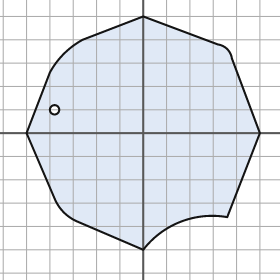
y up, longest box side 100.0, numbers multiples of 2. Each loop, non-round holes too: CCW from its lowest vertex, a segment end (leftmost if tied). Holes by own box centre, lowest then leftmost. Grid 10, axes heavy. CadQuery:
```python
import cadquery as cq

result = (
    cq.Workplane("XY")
    .moveTo(0.0, -50.0)
    .threePointArc((16.0, -38.0), (36.0, -36.0))
    .lineTo(50.0, 0.0)
    .lineTo(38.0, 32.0)
    .threePointArc((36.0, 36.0), (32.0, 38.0))
    .lineTo(0.0, 50.0)
    .lineTo(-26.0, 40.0)
    .threePointArc((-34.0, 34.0), (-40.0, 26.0))
    .lineTo(-50.0, 0.0)
    .lineTo(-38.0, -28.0)
    .threePointArc((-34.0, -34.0), (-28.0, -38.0))
    .close()
    .moveTo(-38.0, 10.0)
    .circle(2.0)
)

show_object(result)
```